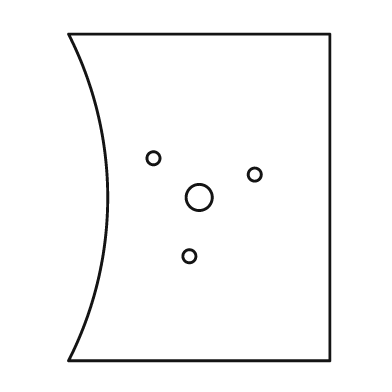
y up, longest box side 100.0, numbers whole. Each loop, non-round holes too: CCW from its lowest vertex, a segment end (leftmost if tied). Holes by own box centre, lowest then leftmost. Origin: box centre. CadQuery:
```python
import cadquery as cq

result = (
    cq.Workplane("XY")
    .moveTo(-40.0, -50.0)
    .lineTo(40.0, -50.0)
    .lineTo(40.0, 50.0)
    .lineTo(-40.0, 50.0)
    .threePointArc((-28.0, 0.0), (-40.0, -50.0))
    .close()
    .moveTo(-3.0, -18.0)
    .circle(2.0)
    .moveTo(0.0, 0.0)
    .circle(4.0)
    .moveTo(17.0, 7.0)
    .circle(2.0)
    .moveTo(-14.0, 12.0)
    .circle(2.0)
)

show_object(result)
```